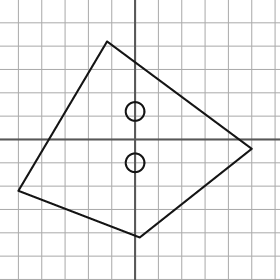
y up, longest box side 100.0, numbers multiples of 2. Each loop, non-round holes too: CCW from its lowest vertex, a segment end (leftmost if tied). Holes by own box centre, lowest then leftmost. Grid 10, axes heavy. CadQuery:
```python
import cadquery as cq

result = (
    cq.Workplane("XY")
    .moveTo(2.0, -42.0)
    .lineTo(50.0, -4.0)
    .lineTo(-12.0, 42.0)
    .lineTo(-50.0, -22.0)
    .close()
    .moveTo(0.0, -10.0)
    .circle(4.0)
    .moveTo(0.0, 12.0)
    .circle(4.0)
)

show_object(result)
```